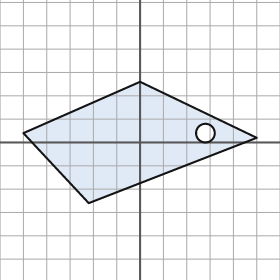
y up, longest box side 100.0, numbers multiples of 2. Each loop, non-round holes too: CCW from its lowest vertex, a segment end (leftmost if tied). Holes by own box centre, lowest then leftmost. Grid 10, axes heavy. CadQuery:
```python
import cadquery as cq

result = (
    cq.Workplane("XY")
    .moveTo(-22.0, -26.0)
    .lineTo(50.0, 2.0)
    .lineTo(0.0, 26.0)
    .lineTo(-50.0, 4.0)
    .close()
    .moveTo(28.0, 4.0)
    .circle(4.0)
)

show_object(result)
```